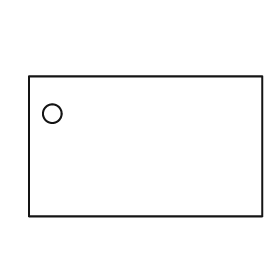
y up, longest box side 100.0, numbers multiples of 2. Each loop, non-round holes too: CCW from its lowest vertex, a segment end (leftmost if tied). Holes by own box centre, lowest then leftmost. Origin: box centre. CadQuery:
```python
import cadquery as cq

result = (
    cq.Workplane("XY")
    .moveTo(-50.0, -30.0)
    .lineTo(50.0, -30.0)
    .lineTo(50.0, 30.0)
    .lineTo(-50.0, 30.0)
    .close()
    .moveTo(-40.0, 14.0)
    .circle(4.0)
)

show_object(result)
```